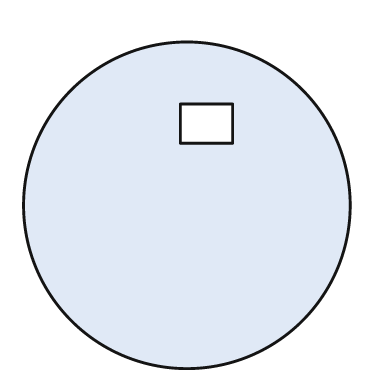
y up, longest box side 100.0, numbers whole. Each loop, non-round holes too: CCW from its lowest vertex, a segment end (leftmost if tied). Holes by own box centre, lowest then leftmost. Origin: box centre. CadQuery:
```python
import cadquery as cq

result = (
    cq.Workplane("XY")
    .moveTo(0.0, 0.0)
    .circle(50.0)
    .moveTo(-2.0, 19.0)
    .lineTo(14.0, 19.0)
    .lineTo(14.0, 31.0)
    .lineTo(-2.0, 31.0)
    .close()
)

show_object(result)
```